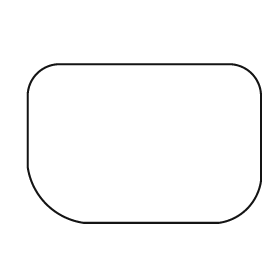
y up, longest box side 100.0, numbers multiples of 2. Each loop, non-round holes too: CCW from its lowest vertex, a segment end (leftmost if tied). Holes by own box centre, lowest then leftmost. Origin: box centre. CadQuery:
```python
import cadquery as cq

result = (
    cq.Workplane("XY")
    .moveTo(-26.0, -34.0)
    .lineTo(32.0, -34.0)
    .threePointArc((44.0, -28.0), (50.0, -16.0))
    .lineTo(50.0, 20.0)
    .threePointArc((46.0, 30.0), (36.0, 34.0))
    .lineTo(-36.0, 34.0)
    .threePointArc((-46.0, 30.0), (-50.0, 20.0))
    .lineTo(-50.0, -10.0)
    .threePointArc((-42.0, -26.0), (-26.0, -34.0))
    .close()
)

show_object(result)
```